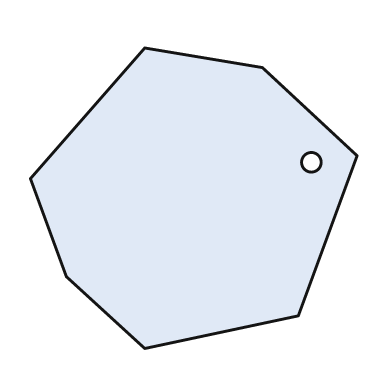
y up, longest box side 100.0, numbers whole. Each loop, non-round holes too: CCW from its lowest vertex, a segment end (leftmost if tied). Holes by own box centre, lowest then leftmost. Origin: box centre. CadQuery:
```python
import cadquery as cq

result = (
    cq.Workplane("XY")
    .moveTo(-15.0, -46.0)
    .lineTo(32.0, -36.0)
    .lineTo(50.0, 13.0)
    .lineTo(21.0, 40.0)
    .lineTo(-15.0, 46.0)
    .lineTo(-50.0, 6.0)
    .lineTo(-39.0, -24.0)
    .close()
    .moveTo(36.0, 11.0)
    .circle(3.0)
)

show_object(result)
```